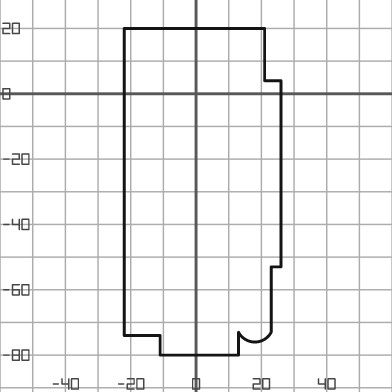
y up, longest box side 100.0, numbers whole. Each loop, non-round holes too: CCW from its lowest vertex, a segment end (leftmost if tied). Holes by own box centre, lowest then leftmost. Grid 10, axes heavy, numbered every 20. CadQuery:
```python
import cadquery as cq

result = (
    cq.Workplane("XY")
    .moveTo(-11.0, -80.0)
    .lineTo(13.0, -80.0)
    .lineTo(13.0, -73.0)
    .threePointArc((18.0, -76.0), (23.0, -73.0))
    .lineTo(23.0, -53.0)
    .lineTo(26.0, -53.0)
    .lineTo(26.0, 4.0)
    .lineTo(21.0, 4.0)
    .lineTo(21.0, 20.0)
    .lineTo(-22.0, 20.0)
    .lineTo(-22.0, -74.0)
    .lineTo(-11.0, -74.0)
    .close()
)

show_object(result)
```